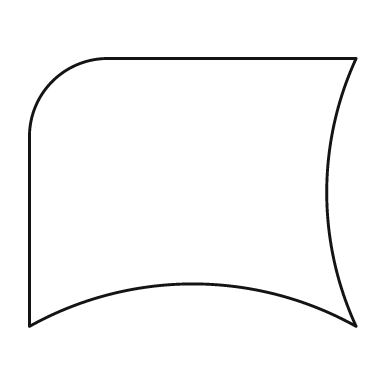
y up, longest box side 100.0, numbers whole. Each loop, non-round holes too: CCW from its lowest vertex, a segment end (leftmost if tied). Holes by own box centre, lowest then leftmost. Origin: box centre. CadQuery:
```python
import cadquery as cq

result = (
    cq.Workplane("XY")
    .moveTo(-50.0, -41.0)
    .threePointArc((0.0, -28.0), (50.0, -41.0))
    .threePointArc((41.0, 0.0), (50.0, 41.0))
    .lineTo(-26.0, 41.0)
    .threePointArc((-43.0, 34.0), (-50.0, 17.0))
    .close()
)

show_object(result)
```